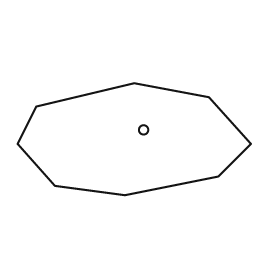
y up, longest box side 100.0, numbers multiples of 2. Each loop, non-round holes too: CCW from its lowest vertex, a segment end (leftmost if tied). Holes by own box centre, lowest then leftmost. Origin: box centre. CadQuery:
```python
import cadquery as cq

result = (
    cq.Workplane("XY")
    .moveTo(-4.0, -24.0)
    .lineTo(36.0, -16.0)
    .lineTo(50.0, -2.0)
    .lineTo(32.0, 18.0)
    .lineTo(0.0, 24.0)
    .lineTo(-42.0, 14.0)
    .lineTo(-50.0, -2.0)
    .lineTo(-34.0, -20.0)
    .close()
    .moveTo(4.0, 4.0)
    .circle(2.0)
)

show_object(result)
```